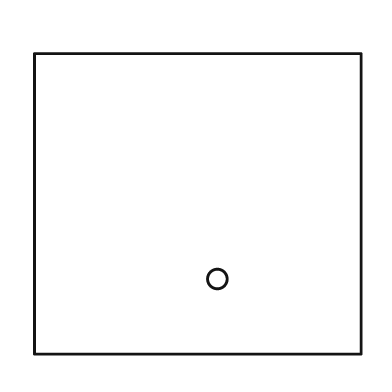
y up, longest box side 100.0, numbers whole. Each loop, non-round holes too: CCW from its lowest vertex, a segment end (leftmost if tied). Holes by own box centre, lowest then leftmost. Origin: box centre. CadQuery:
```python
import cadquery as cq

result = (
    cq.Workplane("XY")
    .moveTo(-50.0, -46.0)
    .lineTo(50.0, -46.0)
    .lineTo(50.0, 46.0)
    .lineTo(-50.0, 46.0)
    .close()
    .moveTo(6.0, -23.0)
    .circle(3.0)
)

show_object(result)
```